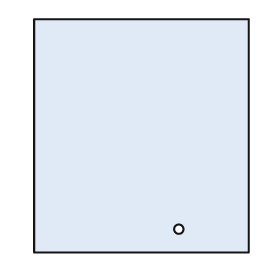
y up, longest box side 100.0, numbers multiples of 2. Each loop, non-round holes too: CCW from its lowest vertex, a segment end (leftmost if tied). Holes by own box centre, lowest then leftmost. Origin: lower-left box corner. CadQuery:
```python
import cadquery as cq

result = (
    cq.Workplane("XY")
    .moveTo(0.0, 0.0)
    .lineTo(92.0, 0.0)
    .lineTo(92.0, 100.0)
    .lineTo(0.0, 100.0)
    .close()
    .moveTo(62.0, 10.0)
    .circle(2.0)
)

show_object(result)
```